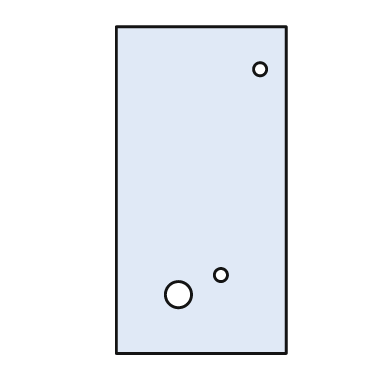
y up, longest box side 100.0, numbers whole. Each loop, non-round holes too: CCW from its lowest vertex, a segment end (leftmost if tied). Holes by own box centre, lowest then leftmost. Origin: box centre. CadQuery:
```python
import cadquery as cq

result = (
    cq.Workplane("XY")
    .moveTo(-26.0, -50.0)
    .lineTo(26.0, -50.0)
    .lineTo(26.0, 50.0)
    .lineTo(-26.0, 50.0)
    .close()
    .moveTo(-7.0, -32.0)
    .circle(4.0)
    .moveTo(6.0, -26.0)
    .circle(2.0)
    .moveTo(18.0, 37.0)
    .circle(2.0)
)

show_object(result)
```